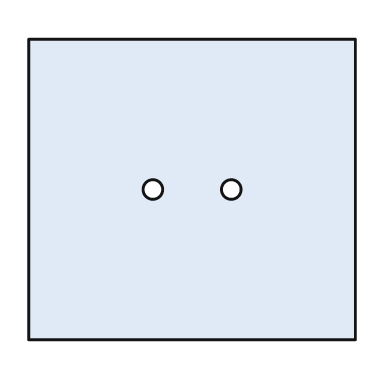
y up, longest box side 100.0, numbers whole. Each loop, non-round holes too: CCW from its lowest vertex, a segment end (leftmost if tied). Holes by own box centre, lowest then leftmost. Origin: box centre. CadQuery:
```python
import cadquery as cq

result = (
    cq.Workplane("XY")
    .moveTo(-50.0, -46.0)
    .lineTo(50.0, -46.0)
    .lineTo(50.0, 46.0)
    .lineTo(-50.0, 46.0)
    .close()
    .moveTo(-12.0, 0.0)
    .circle(3.0)
    .moveTo(12.0, 0.0)
    .circle(3.0)
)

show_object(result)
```